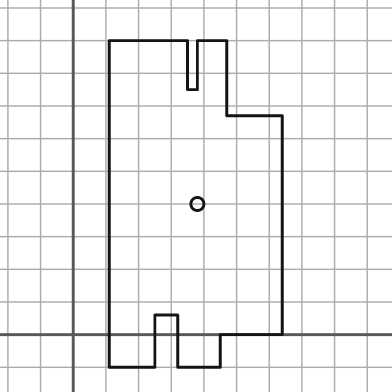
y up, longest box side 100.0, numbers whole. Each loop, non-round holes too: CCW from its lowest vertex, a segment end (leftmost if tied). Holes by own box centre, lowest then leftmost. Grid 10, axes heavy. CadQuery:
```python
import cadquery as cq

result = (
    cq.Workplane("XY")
    .moveTo(11.0, -10.0)
    .lineTo(25.0, -10.0)
    .lineTo(25.0, 6.0)
    .lineTo(32.0, 6.0)
    .lineTo(32.0, -10.0)
    .lineTo(45.0, -10.0)
    .lineTo(45.0, 0.0)
    .lineTo(64.0, 0.0)
    .lineTo(64.0, 67.0)
    .lineTo(47.0, 67.0)
    .lineTo(47.0, 90.0)
    .lineTo(38.0, 90.0)
    .lineTo(38.0, 75.0)
    .lineTo(35.0, 75.0)
    .lineTo(35.0, 90.0)
    .lineTo(11.0, 90.0)
    .close()
    .moveTo(38.0, 40.0)
    .circle(2.0)
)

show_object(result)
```